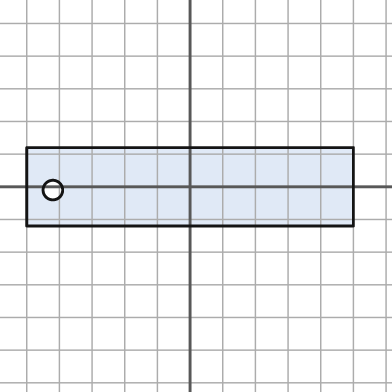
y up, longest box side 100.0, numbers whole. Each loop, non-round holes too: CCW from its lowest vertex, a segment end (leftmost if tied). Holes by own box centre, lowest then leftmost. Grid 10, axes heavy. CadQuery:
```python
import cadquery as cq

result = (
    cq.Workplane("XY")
    .moveTo(-50.0, -12.0)
    .lineTo(50.0, -12.0)
    .lineTo(50.0, 12.0)
    .lineTo(-50.0, 12.0)
    .close()
    .moveTo(-42.0, -1.0)
    .circle(3.0)
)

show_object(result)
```